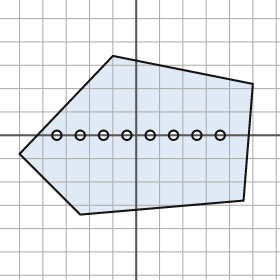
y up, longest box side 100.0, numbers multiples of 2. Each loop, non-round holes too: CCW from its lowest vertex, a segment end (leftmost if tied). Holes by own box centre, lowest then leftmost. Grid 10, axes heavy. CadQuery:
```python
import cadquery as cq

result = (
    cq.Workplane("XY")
    .moveTo(-24.0, -34.0)
    .lineTo(46.0, -28.0)
    .lineTo(50.0, 22.0)
    .lineTo(-10.0, 34.0)
    .lineTo(-50.0, -8.0)
    .close()
    .moveTo(-34.0, 0.0)
    .circle(2.0)
    .moveTo(-24.0, 0.0)
    .circle(2.0)
    .moveTo(-14.0, 0.0)
    .circle(2.0)
    .moveTo(-4.0, 0.0)
    .circle(2.0)
    .moveTo(6.0, 0.0)
    .circle(2.0)
    .moveTo(16.0, 0.0)
    .circle(2.0)
    .moveTo(26.0, 0.0)
    .circle(2.0)
    .moveTo(36.0, 0.0)
    .circle(2.0)
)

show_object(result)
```